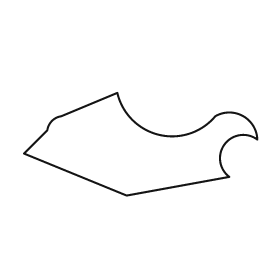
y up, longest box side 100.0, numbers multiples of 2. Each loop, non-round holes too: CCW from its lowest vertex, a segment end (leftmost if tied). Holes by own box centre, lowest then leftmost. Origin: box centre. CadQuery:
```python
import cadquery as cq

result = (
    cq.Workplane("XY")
    .moveTo(-6.0, -22.0)
    .lineTo(38.0, -14.0)
    .threePointArc((36.0, 0.0), (50.0, 2.0))
    .threePointArc((44.0, 12.0), (32.0, 12.0))
    .threePointArc((8.0, 4.0), (-10.0, 22.0))
    .lineTo(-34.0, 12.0)
    .threePointArc((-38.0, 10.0), (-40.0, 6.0))
    .lineTo(-50.0, -4.0)
    .close()
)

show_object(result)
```